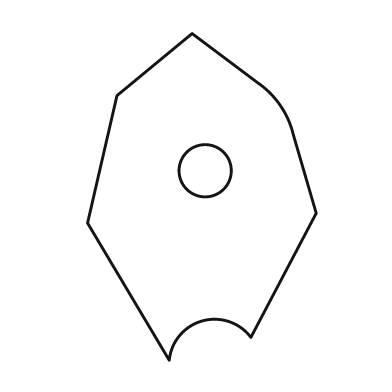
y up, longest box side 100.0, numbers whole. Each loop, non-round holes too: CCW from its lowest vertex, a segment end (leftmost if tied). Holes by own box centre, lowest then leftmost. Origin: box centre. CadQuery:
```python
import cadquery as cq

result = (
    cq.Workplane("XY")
    .moveTo(-10.0, -50.0)
    .threePointArc((0.0, -38.0), (15.0, -43.0))
    .lineTo(35.0, -5.0)
    .lineTo(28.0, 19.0)
    .threePointArc((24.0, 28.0), (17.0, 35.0))
    .lineTo(-3.0, 50.0)
    .lineTo(-26.0, 31.0)
    .lineTo(-35.0, -8.0)
    .close()
    .moveTo(1.0, 8.0)
    .circle(8.0)
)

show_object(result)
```